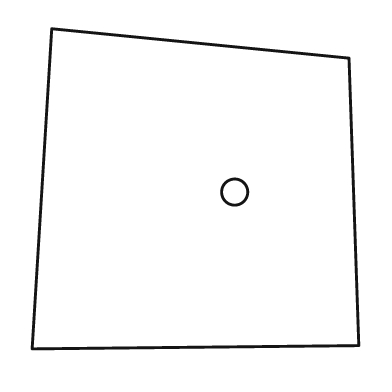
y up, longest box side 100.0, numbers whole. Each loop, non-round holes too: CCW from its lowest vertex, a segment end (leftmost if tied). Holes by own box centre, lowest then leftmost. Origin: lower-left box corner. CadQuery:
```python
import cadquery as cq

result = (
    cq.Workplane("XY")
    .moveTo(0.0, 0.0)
    .lineTo(100.0, 1.0)
    .lineTo(97.0, 89.0)
    .lineTo(6.0, 98.0)
    .close()
    .moveTo(62.0, 48.0)
    .circle(4.0)
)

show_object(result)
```